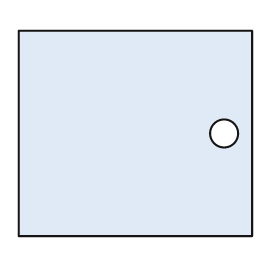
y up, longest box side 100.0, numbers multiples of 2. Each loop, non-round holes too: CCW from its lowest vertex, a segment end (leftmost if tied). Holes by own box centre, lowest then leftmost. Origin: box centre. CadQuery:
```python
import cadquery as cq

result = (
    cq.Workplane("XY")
    .moveTo(-50.0, -44.0)
    .lineTo(50.0, -44.0)
    .lineTo(50.0, 44.0)
    .lineTo(-50.0, 44.0)
    .close()
    .moveTo(38.0, 0.0)
    .circle(6.0)
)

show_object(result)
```